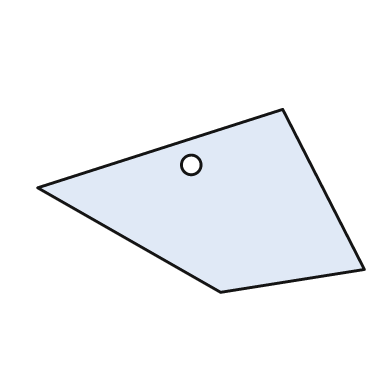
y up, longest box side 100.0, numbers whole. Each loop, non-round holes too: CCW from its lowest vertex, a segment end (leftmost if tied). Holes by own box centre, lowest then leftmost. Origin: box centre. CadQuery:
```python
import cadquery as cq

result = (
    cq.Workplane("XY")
    .moveTo(6.0, -28.0)
    .lineTo(50.0, -21.0)
    .lineTo(25.0, 28.0)
    .lineTo(-50.0, 4.0)
    .close()
    .moveTo(-3.0, 11.0)
    .circle(3.0)
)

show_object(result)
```